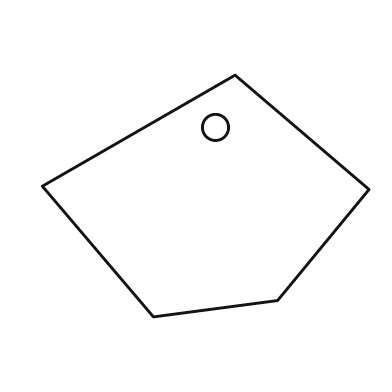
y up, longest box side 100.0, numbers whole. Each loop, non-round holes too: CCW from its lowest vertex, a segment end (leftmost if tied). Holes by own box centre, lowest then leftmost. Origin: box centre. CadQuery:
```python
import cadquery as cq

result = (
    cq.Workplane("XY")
    .moveTo(-16.0, -37.0)
    .lineTo(22.0, -32.0)
    .lineTo(50.0, 2.0)
    .lineTo(9.0, 37.0)
    .lineTo(-50.0, 3.0)
    .close()
    .moveTo(3.0, 21.0)
    .circle(4.0)
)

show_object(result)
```